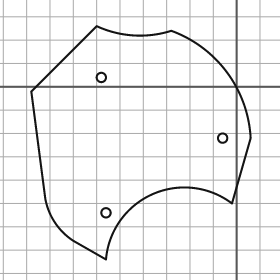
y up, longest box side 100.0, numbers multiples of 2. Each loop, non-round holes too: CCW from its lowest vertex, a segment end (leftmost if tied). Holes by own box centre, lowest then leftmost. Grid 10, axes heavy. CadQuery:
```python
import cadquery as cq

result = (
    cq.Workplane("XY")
    .moveTo(-56.0, -74.0)
    .threePointArc((-36.0, -46.0), (-2.0, -50.0))
    .lineTo(6.0, -22.0)
    .threePointArc((-4.0, 6.0), (-28.0, 24.0))
    .threePointArc((-44.0, 22.0), (-60.0, 26.0))
    .lineTo(-88.0, -2.0)
    .lineTo(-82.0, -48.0)
    .threePointArc((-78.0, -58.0), (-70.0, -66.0))
    .close()
    .moveTo(-56.0, -54.0)
    .circle(2.0)
    .moveTo(-6.0, -22.0)
    .circle(2.0)
    .moveTo(-58.0, 4.0)
    .circle(2.0)
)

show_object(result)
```